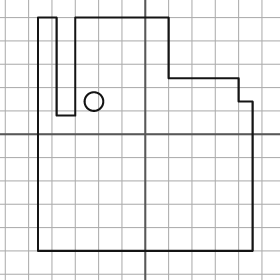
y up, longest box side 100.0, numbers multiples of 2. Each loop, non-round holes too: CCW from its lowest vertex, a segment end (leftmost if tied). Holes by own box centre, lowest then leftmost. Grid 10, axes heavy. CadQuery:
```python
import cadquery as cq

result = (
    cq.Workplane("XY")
    .moveTo(-46.0, -50.0)
    .lineTo(46.0, -50.0)
    .lineTo(46.0, 14.0)
    .lineTo(40.0, 14.0)
    .lineTo(40.0, 24.0)
    .lineTo(10.0, 24.0)
    .lineTo(10.0, 50.0)
    .lineTo(-30.0, 50.0)
    .lineTo(-30.0, 8.0)
    .lineTo(-38.0, 8.0)
    .lineTo(-38.0, 50.0)
    .lineTo(-46.0, 50.0)
    .close()
    .moveTo(-22.0, 14.0)
    .circle(4.0)
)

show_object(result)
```